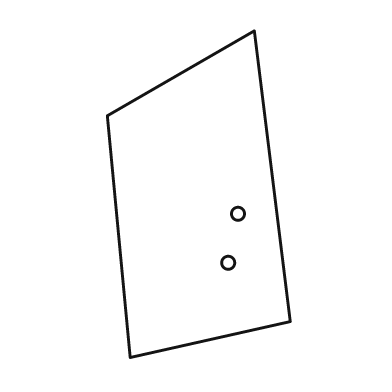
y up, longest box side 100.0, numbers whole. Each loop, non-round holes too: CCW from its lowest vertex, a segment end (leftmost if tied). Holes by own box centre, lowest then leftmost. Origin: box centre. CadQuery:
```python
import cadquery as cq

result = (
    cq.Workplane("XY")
    .moveTo(-21.0, -50.0)
    .lineTo(28.0, -39.0)
    .lineTo(17.0, 50.0)
    .lineTo(-28.0, 24.0)
    .close()
    .moveTo(9.0, -21.0)
    .circle(2.0)
    .moveTo(12.0, -6.0)
    .circle(2.0)
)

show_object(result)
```